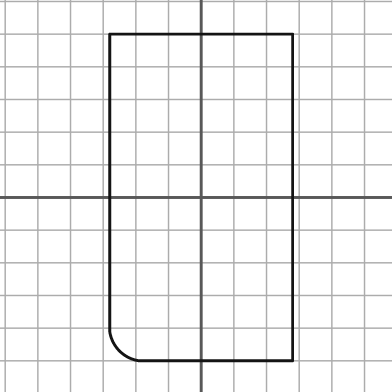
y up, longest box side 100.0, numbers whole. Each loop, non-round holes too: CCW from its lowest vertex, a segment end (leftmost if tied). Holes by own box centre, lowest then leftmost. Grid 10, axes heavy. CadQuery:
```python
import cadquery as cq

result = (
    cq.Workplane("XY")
    .moveTo(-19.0, -50.0)
    .lineTo(28.0, -50.0)
    .lineTo(28.0, 50.0)
    .lineTo(-28.0, 50.0)
    .lineTo(-28.0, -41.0)
    .threePointArc((-25.0, -47.0), (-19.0, -50.0))
    .close()
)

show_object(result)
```